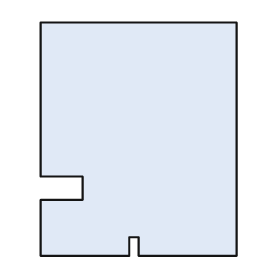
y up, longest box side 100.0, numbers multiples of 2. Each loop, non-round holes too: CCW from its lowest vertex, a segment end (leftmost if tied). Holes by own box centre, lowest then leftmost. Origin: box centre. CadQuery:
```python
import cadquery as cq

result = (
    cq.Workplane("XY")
    .moveTo(-42.0, -50.0)
    .lineTo(-4.0, -50.0)
    .lineTo(-4.0, -42.0)
    .lineTo(0.0, -42.0)
    .lineTo(0.0, -50.0)
    .lineTo(42.0, -50.0)
    .lineTo(42.0, 50.0)
    .lineTo(-42.0, 50.0)
    .lineTo(-42.0, -16.0)
    .lineTo(-24.0, -16.0)
    .lineTo(-24.0, -26.0)
    .lineTo(-42.0, -26.0)
    .close()
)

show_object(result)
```